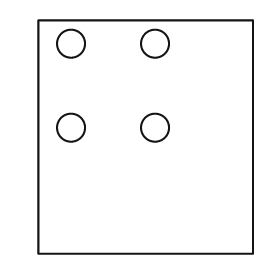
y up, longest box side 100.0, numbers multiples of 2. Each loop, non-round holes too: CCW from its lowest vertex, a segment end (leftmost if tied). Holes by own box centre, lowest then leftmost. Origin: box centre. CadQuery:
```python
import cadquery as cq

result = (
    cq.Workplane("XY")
    .moveTo(-46.0, -50.0)
    .lineTo(46.0, -50.0)
    .lineTo(46.0, 50.0)
    .lineTo(-46.0, 50.0)
    .close()
    .moveTo(-32.0, 4.0)
    .circle(6.0)
    .moveTo(4.0, 4.0)
    .circle(6.0)
    .moveTo(-32.0, 40.0)
    .circle(6.0)
    .moveTo(4.0, 40.0)
    .circle(6.0)
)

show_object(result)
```